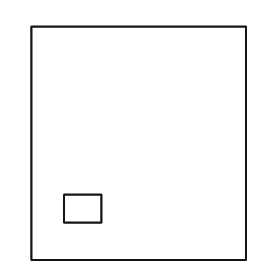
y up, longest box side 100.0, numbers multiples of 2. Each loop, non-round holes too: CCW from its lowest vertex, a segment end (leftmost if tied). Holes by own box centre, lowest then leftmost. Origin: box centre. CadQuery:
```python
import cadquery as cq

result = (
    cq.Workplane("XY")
    .moveTo(-46.0, -50.0)
    .lineTo(46.0, -50.0)
    .lineTo(46.0, 50.0)
    .lineTo(-46.0, 50.0)
    .close()
    .moveTo(-32.0, -34.0)
    .lineTo(-16.0, -34.0)
    .lineTo(-16.0, -22.0)
    .lineTo(-32.0, -22.0)
    .close()
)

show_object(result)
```